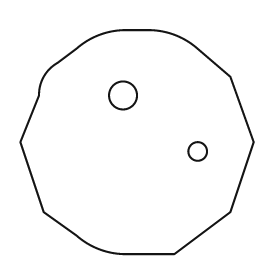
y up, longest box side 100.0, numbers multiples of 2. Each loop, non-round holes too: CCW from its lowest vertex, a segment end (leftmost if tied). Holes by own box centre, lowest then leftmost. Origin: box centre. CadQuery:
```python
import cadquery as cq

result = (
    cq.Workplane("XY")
    .moveTo(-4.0, -48.0)
    .lineTo(16.0, -48.0)
    .lineTo(40.0, -30.0)
    .lineTo(50.0, 0.0)
    .lineTo(40.0, 28.0)
    .lineTo(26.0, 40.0)
    .threePointArc((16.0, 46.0), (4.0, 48.0))
    .lineTo(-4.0, 48.0)
    .threePointArc((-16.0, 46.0), (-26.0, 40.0))
    .lineTo(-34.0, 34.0)
    .threePointArc((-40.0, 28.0), (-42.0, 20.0))
    .lineTo(-50.0, 0.0)
    .lineTo(-40.0, -30.0)
    .lineTo(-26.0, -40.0)
    .threePointArc((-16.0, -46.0), (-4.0, -48.0))
    .close()
    .moveTo(26.0, -4.0)
    .circle(4.0)
    .moveTo(-6.0, 20.0)
    .circle(6.0)
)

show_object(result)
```